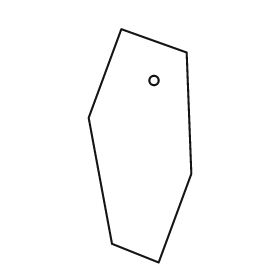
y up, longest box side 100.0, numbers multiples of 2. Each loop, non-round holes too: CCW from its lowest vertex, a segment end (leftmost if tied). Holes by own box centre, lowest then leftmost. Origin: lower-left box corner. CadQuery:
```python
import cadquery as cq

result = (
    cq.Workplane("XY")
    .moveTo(30.0, 0.0)
    .lineTo(44.0, 38.0)
    .lineTo(42.0, 90.0)
    .lineTo(14.0, 100.0)
    .lineTo(0.0, 62.0)
    .lineTo(10.0, 8.0)
    .close()
    .moveTo(28.0, 78.0)
    .circle(2.0)
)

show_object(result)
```